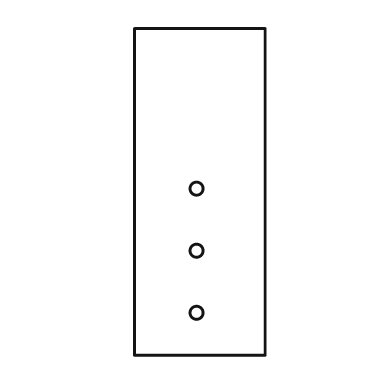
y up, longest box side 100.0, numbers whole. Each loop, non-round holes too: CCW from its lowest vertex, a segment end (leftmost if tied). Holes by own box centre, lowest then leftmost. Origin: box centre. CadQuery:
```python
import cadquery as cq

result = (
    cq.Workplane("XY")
    .moveTo(-20.0, -50.0)
    .lineTo(20.0, -50.0)
    .lineTo(20.0, 50.0)
    .lineTo(-20.0, 50.0)
    .close()
    .moveTo(-1.0, -37.0)
    .circle(2.0)
    .moveTo(-1.0, -18.0)
    .circle(2.0)
    .moveTo(-1.0, 1.0)
    .circle(2.0)
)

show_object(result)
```